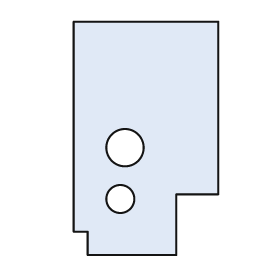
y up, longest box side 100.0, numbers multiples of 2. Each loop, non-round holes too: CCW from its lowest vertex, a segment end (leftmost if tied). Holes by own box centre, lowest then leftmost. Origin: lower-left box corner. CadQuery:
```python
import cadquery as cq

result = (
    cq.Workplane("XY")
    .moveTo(6.0, 0.0)
    .lineTo(44.0, 0.0)
    .lineTo(44.0, 26.0)
    .lineTo(62.0, 26.0)
    .lineTo(62.0, 100.0)
    .lineTo(0.0, 100.0)
    .lineTo(0.0, 10.0)
    .lineTo(6.0, 10.0)
    .close()
    .moveTo(20.0, 24.0)
    .circle(6.0)
    .moveTo(22.0, 46.0)
    .circle(8.0)
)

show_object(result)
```